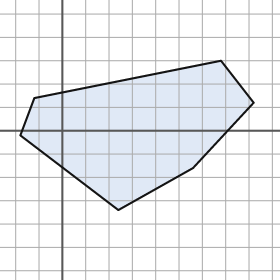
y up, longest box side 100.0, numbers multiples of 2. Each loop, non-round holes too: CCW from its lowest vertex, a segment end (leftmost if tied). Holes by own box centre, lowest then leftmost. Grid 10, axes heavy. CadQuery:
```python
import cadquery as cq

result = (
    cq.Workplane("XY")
    .moveTo(24.0, -34.0)
    .lineTo(56.0, -16.0)
    .lineTo(82.0, 12.0)
    .lineTo(68.0, 30.0)
    .lineTo(-12.0, 14.0)
    .lineTo(-18.0, -2.0)
    .close()
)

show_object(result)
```